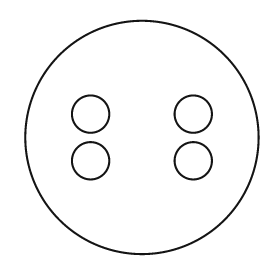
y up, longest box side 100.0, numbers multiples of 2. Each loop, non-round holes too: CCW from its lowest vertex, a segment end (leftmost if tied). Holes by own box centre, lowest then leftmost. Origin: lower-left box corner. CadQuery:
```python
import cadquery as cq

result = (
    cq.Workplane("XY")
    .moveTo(50.0, 50.0)
    .circle(50.0)
    .moveTo(28.0, 40.0)
    .circle(8.0)
    .moveTo(72.0, 40.0)
    .circle(8.0)
    .moveTo(28.0, 60.0)
    .circle(8.0)
    .moveTo(72.0, 60.0)
    .circle(8.0)
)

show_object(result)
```